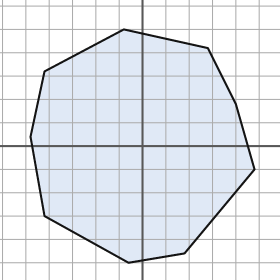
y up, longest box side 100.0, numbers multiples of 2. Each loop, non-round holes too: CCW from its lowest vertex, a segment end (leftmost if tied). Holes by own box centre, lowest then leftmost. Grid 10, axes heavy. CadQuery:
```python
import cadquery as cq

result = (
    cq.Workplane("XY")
    .moveTo(-6.0, -50.0)
    .lineTo(18.0, -46.0)
    .lineTo(48.0, -10.0)
    .lineTo(40.0, 18.0)
    .lineTo(28.0, 42.0)
    .lineTo(-8.0, 50.0)
    .lineTo(-42.0, 32.0)
    .lineTo(-48.0, 4.0)
    .lineTo(-42.0, -30.0)
    .close()
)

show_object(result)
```